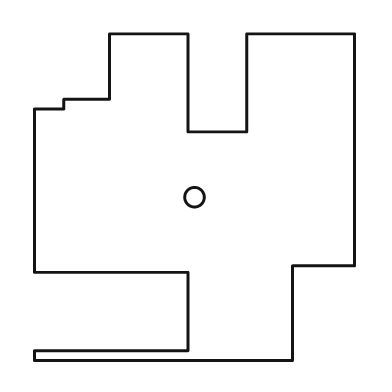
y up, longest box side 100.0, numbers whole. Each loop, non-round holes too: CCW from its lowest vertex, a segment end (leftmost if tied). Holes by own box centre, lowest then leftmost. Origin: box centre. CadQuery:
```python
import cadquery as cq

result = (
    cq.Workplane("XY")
    .moveTo(-49.0, -50.0)
    .lineTo(30.0, -50.0)
    .lineTo(30.0, -21.0)
    .lineTo(49.0, -21.0)
    .lineTo(49.0, 50.0)
    .lineTo(16.0, 50.0)
    .lineTo(16.0, 20.0)
    .lineTo(-2.0, 20.0)
    .lineTo(-2.0, 50.0)
    .lineTo(-26.0, 50.0)
    .lineTo(-26.0, 30.0)
    .lineTo(-40.0, 30.0)
    .lineTo(-40.0, 27.0)
    .lineTo(-49.0, 27.0)
    .lineTo(-49.0, -23.0)
    .lineTo(-2.0, -23.0)
    .lineTo(-2.0, -47.0)
    .lineTo(-49.0, -47.0)
    .close()
    .moveTo(0.0, 0.0)
    .circle(3.0)
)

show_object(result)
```